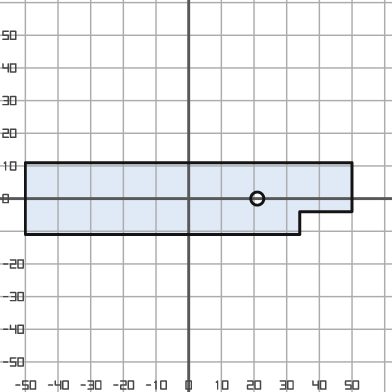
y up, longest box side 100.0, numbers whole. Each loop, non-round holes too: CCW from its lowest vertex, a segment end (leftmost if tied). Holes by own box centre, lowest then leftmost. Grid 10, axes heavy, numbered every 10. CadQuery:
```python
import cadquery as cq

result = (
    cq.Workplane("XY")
    .moveTo(-50.0, -11.0)
    .lineTo(34.0, -11.0)
    .lineTo(34.0, -4.0)
    .lineTo(50.0, -4.0)
    .lineTo(50.0, 11.0)
    .lineTo(-50.0, 11.0)
    .close()
    .moveTo(21.0, 0.0)
    .circle(2.0)
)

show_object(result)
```